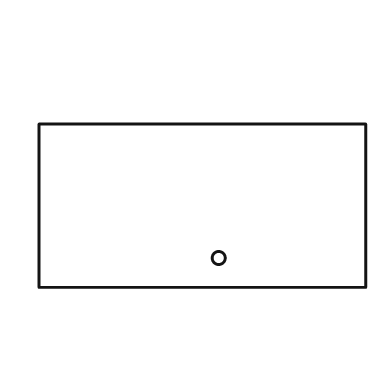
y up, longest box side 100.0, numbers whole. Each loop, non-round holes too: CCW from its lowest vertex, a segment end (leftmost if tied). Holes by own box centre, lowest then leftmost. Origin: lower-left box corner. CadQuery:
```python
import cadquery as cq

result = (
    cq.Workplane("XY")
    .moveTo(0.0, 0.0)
    .lineTo(100.0, 0.0)
    .lineTo(100.0, 50.0)
    .lineTo(0.0, 50.0)
    .close()
    .moveTo(55.0, 9.0)
    .circle(2.0)
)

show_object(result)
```